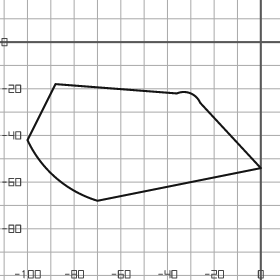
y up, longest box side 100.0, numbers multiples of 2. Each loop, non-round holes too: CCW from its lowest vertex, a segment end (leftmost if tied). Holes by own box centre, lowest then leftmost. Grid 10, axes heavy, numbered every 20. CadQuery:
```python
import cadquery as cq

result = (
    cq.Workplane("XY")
    .moveTo(-70.0, -68.0)
    .lineTo(0.0, -54.0)
    .lineTo(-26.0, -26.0)
    .threePointArc((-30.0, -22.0), (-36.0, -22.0))
    .lineTo(-88.0, -18.0)
    .lineTo(-100.0, -42.0)
    .threePointArc((-88.0, -58.0), (-70.0, -68.0))
    .close()
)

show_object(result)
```